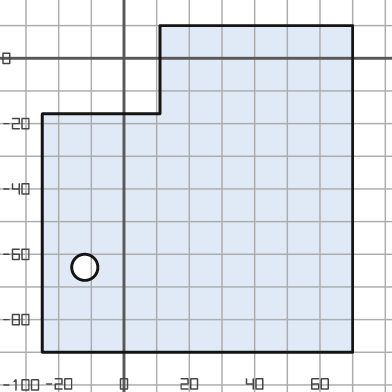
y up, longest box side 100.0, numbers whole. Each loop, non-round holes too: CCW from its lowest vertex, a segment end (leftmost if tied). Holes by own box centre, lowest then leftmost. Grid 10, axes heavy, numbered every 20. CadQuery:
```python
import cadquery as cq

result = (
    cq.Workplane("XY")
    .moveTo(-25.0, -90.0)
    .lineTo(70.0, -90.0)
    .lineTo(70.0, 10.0)
    .lineTo(11.0, 10.0)
    .lineTo(11.0, -17.0)
    .lineTo(-25.0, -17.0)
    .close()
    .moveTo(-12.0, -64.0)
    .circle(4.0)
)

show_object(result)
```